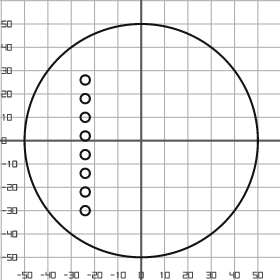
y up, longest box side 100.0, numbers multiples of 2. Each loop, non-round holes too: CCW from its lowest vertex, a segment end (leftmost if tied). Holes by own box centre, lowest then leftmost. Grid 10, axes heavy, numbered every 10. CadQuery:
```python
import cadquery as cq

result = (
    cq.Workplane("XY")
    .moveTo(0.0, 0.0)
    .circle(50.0)
    .moveTo(-24.0, -30.0)
    .circle(2.0)
    .moveTo(-24.0, -22.0)
    .circle(2.0)
    .moveTo(-24.0, -14.0)
    .circle(2.0)
    .moveTo(-24.0, -6.0)
    .circle(2.0)
    .moveTo(-24.0, 2.0)
    .circle(2.0)
    .moveTo(-24.0, 10.0)
    .circle(2.0)
    .moveTo(-24.0, 18.0)
    .circle(2.0)
    .moveTo(-24.0, 26.0)
    .circle(2.0)
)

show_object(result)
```